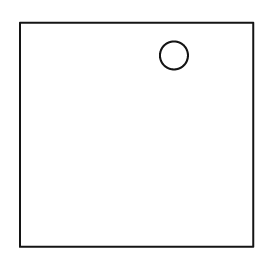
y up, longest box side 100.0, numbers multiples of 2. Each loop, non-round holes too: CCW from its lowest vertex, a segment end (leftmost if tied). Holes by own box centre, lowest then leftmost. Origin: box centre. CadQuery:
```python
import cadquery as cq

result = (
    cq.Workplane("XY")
    .moveTo(-50.0, -48.0)
    .lineTo(50.0, -48.0)
    .lineTo(50.0, 48.0)
    .lineTo(-50.0, 48.0)
    .close()
    .moveTo(16.0, 34.0)
    .circle(6.0)
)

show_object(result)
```